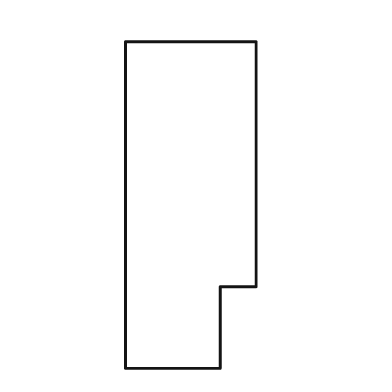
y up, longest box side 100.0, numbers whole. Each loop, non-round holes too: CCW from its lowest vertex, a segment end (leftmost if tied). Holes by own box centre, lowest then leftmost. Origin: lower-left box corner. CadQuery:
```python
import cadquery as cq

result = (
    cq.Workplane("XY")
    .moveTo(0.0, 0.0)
    .lineTo(29.0, 0.0)
    .lineTo(29.0, 25.0)
    .lineTo(40.0, 25.0)
    .lineTo(40.0, 100.0)
    .lineTo(0.0, 100.0)
    .close()
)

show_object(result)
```